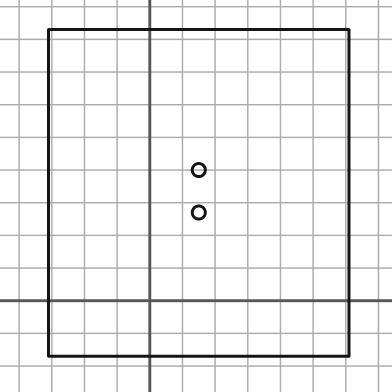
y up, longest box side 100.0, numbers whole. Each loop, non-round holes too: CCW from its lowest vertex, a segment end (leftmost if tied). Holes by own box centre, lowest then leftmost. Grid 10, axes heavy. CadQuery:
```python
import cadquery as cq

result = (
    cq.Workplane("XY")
    .moveTo(-31.0, -17.0)
    .lineTo(61.0, -17.0)
    .lineTo(61.0, 83.0)
    .lineTo(-31.0, 83.0)
    .close()
    .moveTo(15.0, 27.0)
    .circle(2.0)
    .moveTo(15.0, 40.0)
    .circle(2.0)
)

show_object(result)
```